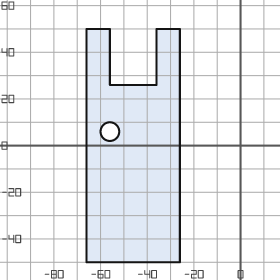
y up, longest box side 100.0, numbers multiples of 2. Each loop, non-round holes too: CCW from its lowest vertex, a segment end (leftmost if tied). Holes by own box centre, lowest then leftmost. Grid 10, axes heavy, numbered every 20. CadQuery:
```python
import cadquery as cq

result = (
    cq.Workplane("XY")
    .moveTo(-66.0, -50.0)
    .lineTo(-26.0, -50.0)
    .lineTo(-26.0, 50.0)
    .lineTo(-36.0, 50.0)
    .lineTo(-36.0, 26.0)
    .lineTo(-56.0, 26.0)
    .lineTo(-56.0, 50.0)
    .lineTo(-66.0, 50.0)
    .close()
    .moveTo(-56.0, 6.0)
    .circle(4.0)
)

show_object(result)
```